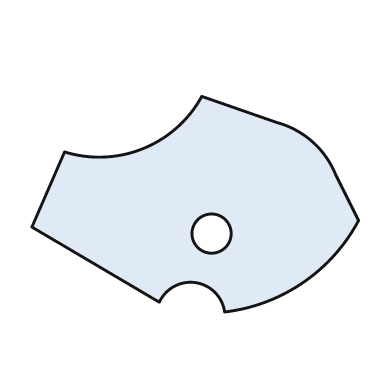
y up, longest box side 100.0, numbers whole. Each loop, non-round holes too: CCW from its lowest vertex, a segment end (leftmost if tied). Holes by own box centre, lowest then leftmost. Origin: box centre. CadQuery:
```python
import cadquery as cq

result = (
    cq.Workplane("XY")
    .moveTo(9.0, -33.0)
    .threePointArc((33.0, -24.0), (50.0, -5.0))
    .lineTo(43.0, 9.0)
    .threePointArc((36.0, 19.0), (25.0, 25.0))
    .lineTo(2.0, 33.0)
    .threePointArc((-16.0, 17.0), (-40.0, 16.0))
    .lineTo(-50.0, -7.0)
    .lineTo(-11.0, -30.0)
    .threePointArc((0.0, -24.0), (9.0, -33.0))
    .close()
    .moveTo(5.0, -9.0)
    .circle(6.0)
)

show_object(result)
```